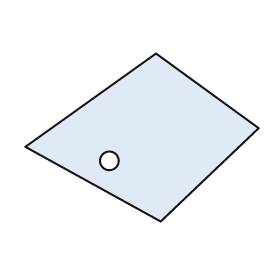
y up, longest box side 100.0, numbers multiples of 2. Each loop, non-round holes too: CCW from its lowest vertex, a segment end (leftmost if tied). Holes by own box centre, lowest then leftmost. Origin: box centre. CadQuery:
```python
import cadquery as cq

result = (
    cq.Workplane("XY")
    .moveTo(8.0, -36.0)
    .lineTo(50.0, 4.0)
    .lineTo(6.0, 36.0)
    .lineTo(-50.0, -4.0)
    .close()
    .moveTo(-14.0, -10.0)
    .circle(4.0)
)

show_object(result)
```